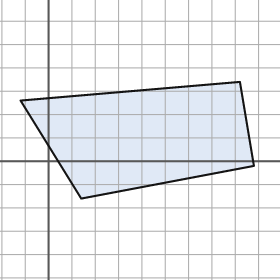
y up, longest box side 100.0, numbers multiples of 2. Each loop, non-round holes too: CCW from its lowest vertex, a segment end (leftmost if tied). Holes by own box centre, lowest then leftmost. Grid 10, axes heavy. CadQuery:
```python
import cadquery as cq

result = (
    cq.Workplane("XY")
    .moveTo(14.0, -16.0)
    .lineTo(88.0, -2.0)
    .lineTo(82.0, 34.0)
    .lineTo(-12.0, 26.0)
    .close()
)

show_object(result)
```